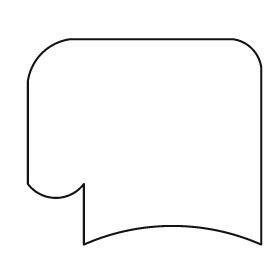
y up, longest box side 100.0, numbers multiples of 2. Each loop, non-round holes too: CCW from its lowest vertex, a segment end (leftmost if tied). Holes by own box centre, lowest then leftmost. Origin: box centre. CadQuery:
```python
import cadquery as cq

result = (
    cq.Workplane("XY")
    .moveTo(-26.0, -44.0)
    .threePointArc((12.0, -36.0), (50.0, -44.0))
    .lineTo(50.0, 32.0)
    .threePointArc((46.0, 40.0), (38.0, 44.0))
    .lineTo(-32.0, 44.0)
    .threePointArc((-44.0, 38.0), (-50.0, 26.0))
    .lineTo(-50.0, -18.0)
    .threePointArc((-38.0, -24.0), (-26.0, -18.0))
    .close()
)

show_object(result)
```